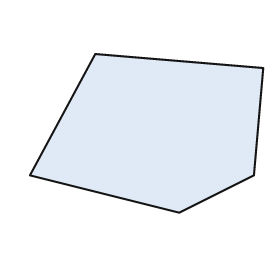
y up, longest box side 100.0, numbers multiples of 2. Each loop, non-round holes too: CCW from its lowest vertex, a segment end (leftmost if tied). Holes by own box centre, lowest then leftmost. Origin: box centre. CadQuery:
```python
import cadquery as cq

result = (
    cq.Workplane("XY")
    .moveTo(14.0, -34.0)
    .lineTo(46.0, -18.0)
    .lineTo(50.0, 28.0)
    .lineTo(-22.0, 34.0)
    .lineTo(-50.0, -18.0)
    .close()
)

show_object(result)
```